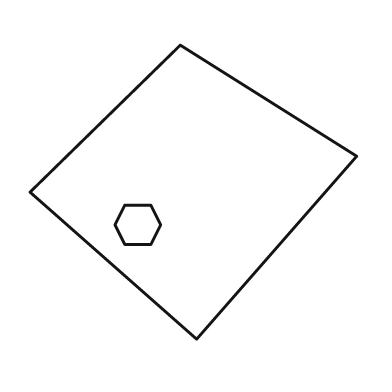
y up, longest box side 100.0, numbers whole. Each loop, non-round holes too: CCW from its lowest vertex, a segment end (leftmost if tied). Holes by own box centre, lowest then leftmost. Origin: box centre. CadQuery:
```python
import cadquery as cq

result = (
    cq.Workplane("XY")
    .moveTo(1.0, -45.0)
    .lineTo(50.0, 11.0)
    .lineTo(-4.0, 45.0)
    .lineTo(-50.0, 0.0)
    .close()
    .moveTo(-21.0, -16.0)
    .lineTo(-13.0, -16.0)
    .lineTo(-10.0, -10.0)
    .lineTo(-13.0, -4.0)
    .lineTo(-21.0, -4.0)
    .lineTo(-24.0, -10.0)
    .close()
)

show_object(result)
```